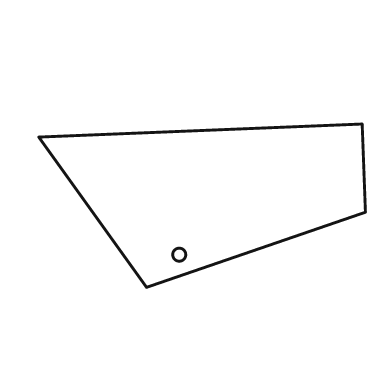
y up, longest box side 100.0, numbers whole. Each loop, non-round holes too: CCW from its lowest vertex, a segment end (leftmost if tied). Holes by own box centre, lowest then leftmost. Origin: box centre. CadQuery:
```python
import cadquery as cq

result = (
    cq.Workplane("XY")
    .moveTo(-17.0, -25.0)
    .lineTo(50.0, -2.0)
    .lineTo(49.0, 25.0)
    .lineTo(-50.0, 21.0)
    .close()
    .moveTo(-7.0, -15.0)
    .circle(2.0)
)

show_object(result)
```